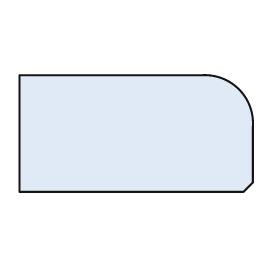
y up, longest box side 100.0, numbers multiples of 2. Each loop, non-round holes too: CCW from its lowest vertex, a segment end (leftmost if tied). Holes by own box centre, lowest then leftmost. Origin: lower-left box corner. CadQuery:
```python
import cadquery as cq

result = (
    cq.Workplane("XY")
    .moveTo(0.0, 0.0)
    .lineTo(96.0, 0.0)
    .lineTo(100.0, 4.0)
    .lineTo(100.0, 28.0)
    .threePointArc((94.0, 44.0), (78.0, 50.0))
    .lineTo(0.0, 50.0)
    .close()
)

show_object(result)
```